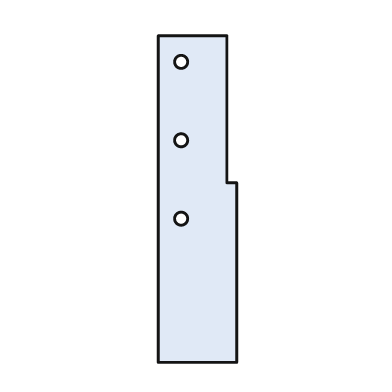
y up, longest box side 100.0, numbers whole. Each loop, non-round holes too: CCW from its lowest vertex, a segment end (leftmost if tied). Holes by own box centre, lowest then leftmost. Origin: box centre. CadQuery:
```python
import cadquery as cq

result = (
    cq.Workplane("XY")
    .moveTo(-12.0, -50.0)
    .lineTo(12.0, -50.0)
    .lineTo(12.0, 5.0)
    .lineTo(9.0, 5.0)
    .lineTo(9.0, 50.0)
    .lineTo(-12.0, 50.0)
    .close()
    .moveTo(-5.0, -6.0)
    .circle(2.0)
    .moveTo(-5.0, 18.0)
    .circle(2.0)
    .moveTo(-5.0, 42.0)
    .circle(2.0)
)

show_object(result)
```